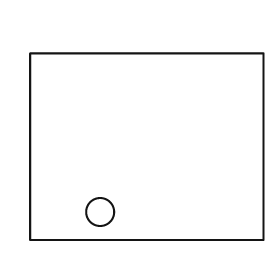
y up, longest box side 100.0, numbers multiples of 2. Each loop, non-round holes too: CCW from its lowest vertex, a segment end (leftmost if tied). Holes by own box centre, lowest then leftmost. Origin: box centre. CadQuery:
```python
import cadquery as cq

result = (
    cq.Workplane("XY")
    .moveTo(-50.0, -40.0)
    .lineTo(50.0, -40.0)
    .lineTo(50.0, 40.0)
    .lineTo(-50.0, 40.0)
    .close()
    .moveTo(-20.0, -28.0)
    .circle(6.0)
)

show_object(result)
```